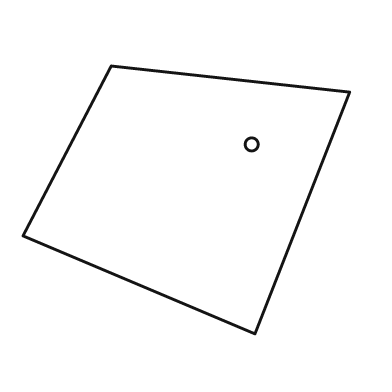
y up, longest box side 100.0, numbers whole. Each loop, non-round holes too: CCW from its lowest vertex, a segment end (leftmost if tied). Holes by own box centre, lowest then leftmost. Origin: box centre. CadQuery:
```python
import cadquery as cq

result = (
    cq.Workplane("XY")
    .moveTo(21.0, -41.0)
    .lineTo(50.0, 33.0)
    .lineTo(-23.0, 41.0)
    .lineTo(-50.0, -11.0)
    .close()
    .moveTo(20.0, 17.0)
    .circle(2.0)
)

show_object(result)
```